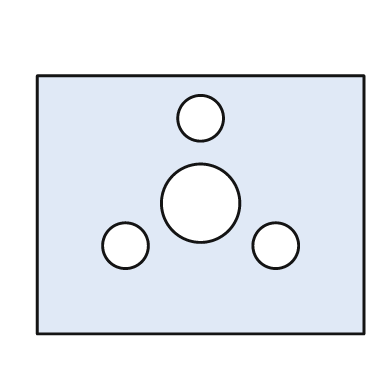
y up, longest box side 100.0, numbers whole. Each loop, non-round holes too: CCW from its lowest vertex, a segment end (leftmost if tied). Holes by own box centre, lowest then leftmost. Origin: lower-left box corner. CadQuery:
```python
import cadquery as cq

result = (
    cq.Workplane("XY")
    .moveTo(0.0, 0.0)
    .lineTo(100.0, 0.0)
    .lineTo(100.0, 79.0)
    .lineTo(0.0, 79.0)
    .close()
    .moveTo(27.0, 27.0)
    .circle(7.0)
    .moveTo(73.0, 27.0)
    .circle(7.0)
    .moveTo(50.0, 40.0)
    .circle(12.0)
    .moveTo(50.0, 66.0)
    .circle(7.0)
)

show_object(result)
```